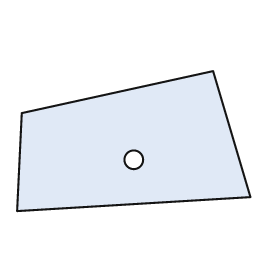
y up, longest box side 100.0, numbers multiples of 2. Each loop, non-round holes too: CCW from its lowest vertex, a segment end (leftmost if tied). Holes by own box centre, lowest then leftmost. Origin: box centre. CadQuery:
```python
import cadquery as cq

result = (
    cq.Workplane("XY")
    .moveTo(-50.0, -30.0)
    .lineTo(50.0, -24.0)
    .lineTo(34.0, 30.0)
    .lineTo(-48.0, 12.0)
    .close()
    .moveTo(0.0, -8.0)
    .circle(4.0)
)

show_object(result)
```